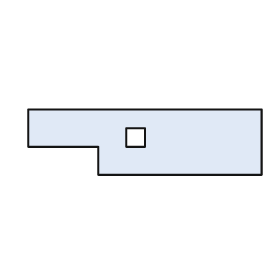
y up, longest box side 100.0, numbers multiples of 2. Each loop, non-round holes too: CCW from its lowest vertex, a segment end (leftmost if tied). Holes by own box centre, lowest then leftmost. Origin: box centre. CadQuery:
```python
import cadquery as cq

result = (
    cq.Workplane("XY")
    .moveTo(-20.0, -14.0)
    .lineTo(50.0, -14.0)
    .lineTo(50.0, 14.0)
    .lineTo(-50.0, 14.0)
    .lineTo(-50.0, -2.0)
    .lineTo(-20.0, -2.0)
    .close()
    .moveTo(-8.0, -2.0)
    .lineTo(0.0, -2.0)
    .lineTo(0.0, 6.0)
    .lineTo(-8.0, 6.0)
    .close()
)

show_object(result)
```